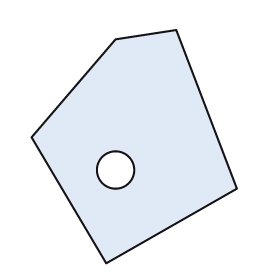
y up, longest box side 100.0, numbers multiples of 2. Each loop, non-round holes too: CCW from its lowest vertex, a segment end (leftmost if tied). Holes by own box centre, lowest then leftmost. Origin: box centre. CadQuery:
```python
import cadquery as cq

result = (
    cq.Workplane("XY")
    .moveTo(-12.0, -50.0)
    .lineTo(44.0, -18.0)
    .lineTo(18.0, 50.0)
    .lineTo(-8.0, 46.0)
    .lineTo(-44.0, 4.0)
    .close()
    .moveTo(-8.0, -10.0)
    .circle(8.0)
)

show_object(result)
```